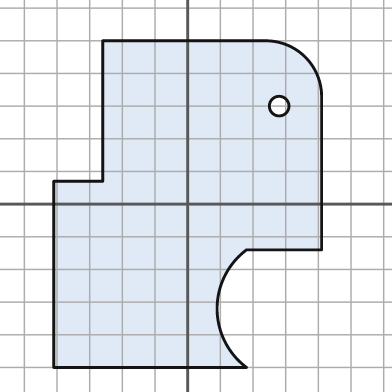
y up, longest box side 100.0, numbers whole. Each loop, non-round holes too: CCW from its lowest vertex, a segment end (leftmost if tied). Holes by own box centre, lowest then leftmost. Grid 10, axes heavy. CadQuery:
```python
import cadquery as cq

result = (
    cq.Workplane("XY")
    .moveTo(-41.0, -50.0)
    .lineTo(18.0, -50.0)
    .threePointArc((9.0, -32.0), (18.0, -14.0))
    .lineTo(41.0, -14.0)
    .lineTo(41.0, 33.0)
    .threePointArc((36.0, 45.0), (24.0, 50.0))
    .lineTo(-26.0, 50.0)
    .lineTo(-26.0, 7.0)
    .lineTo(-41.0, 7.0)
    .close()
    .moveTo(28.0, 30.0)
    .circle(3.0)
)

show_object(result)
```